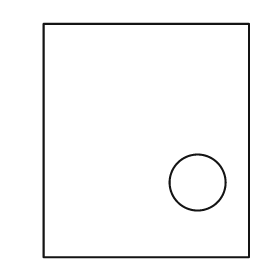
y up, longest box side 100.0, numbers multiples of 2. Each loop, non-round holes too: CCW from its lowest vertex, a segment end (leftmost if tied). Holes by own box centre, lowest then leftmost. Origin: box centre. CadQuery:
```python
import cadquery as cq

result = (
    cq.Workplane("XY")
    .moveTo(-44.0, -50.0)
    .lineTo(44.0, -50.0)
    .lineTo(44.0, 50.0)
    .lineTo(-44.0, 50.0)
    .close()
    .moveTo(22.0, -18.0)
    .circle(12.0)
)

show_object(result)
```